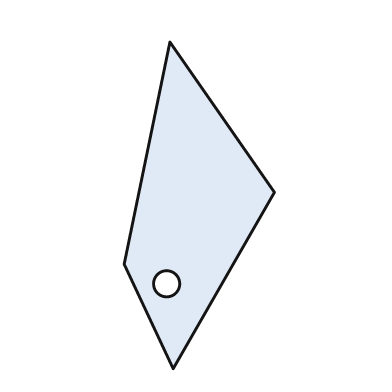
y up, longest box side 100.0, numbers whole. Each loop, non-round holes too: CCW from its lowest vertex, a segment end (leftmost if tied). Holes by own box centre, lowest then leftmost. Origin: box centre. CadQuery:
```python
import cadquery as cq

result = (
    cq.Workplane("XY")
    .moveTo(-8.0, -50.0)
    .lineTo(23.0, 4.0)
    .lineTo(-9.0, 50.0)
    .lineTo(-23.0, -18.0)
    .close()
    .moveTo(-10.0, -24.0)
    .circle(4.0)
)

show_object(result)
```